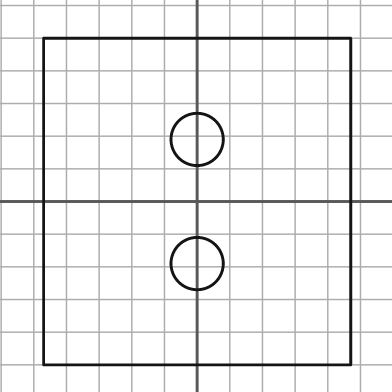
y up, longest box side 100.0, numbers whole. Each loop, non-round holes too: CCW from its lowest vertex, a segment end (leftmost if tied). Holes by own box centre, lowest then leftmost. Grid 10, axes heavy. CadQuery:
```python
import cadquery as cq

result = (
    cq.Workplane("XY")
    .moveTo(-47.0, -50.0)
    .lineTo(47.0, -50.0)
    .lineTo(47.0, 50.0)
    .lineTo(-47.0, 50.0)
    .close()
    .moveTo(0.0, -19.0)
    .circle(8.0)
    .moveTo(0.0, 19.0)
    .circle(8.0)
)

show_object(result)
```